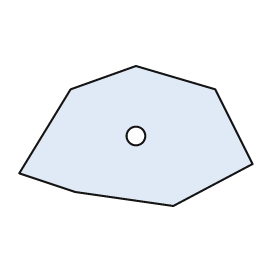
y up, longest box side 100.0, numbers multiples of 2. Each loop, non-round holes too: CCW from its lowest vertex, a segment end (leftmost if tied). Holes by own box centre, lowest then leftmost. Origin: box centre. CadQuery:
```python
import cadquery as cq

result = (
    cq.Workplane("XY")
    .moveTo(16.0, -30.0)
    .lineTo(50.0, -12.0)
    .lineTo(34.0, 20.0)
    .lineTo(0.0, 30.0)
    .lineTo(-28.0, 20.0)
    .lineTo(-50.0, -16.0)
    .lineTo(-26.0, -24.0)
    .close()
    .moveTo(0.0, 0.0)
    .circle(4.0)
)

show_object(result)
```